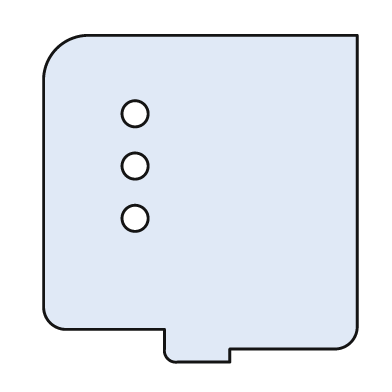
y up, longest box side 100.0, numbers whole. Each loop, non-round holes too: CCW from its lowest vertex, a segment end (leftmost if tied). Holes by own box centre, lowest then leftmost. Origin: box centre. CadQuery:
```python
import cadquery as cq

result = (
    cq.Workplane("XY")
    .moveTo(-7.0, -50.0)
    .lineTo(9.0, -50.0)
    .lineTo(9.0, -46.0)
    .lineTo(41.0, -46.0)
    .threePointArc((46.0, -44.0), (48.0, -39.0))
    .lineTo(48.0, 50.0)
    .lineTo(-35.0, 50.0)
    .threePointArc((-44.0, 46.0), (-48.0, 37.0))
    .lineTo(-48.0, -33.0)
    .threePointArc((-46.0, -38.0), (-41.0, -40.0))
    .lineTo(-11.0, -40.0)
    .lineTo(-11.0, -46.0)
    .threePointArc((-10.0, -49.0), (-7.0, -50.0))
    .close()
    .moveTo(-20.0, -6.0)
    .circle(4.0)
    .moveTo(-20.0, 10.0)
    .circle(4.0)
    .moveTo(-20.0, 26.0)
    .circle(4.0)
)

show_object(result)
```